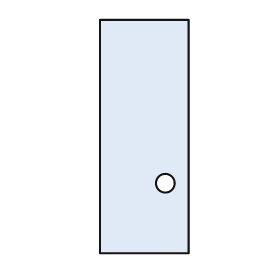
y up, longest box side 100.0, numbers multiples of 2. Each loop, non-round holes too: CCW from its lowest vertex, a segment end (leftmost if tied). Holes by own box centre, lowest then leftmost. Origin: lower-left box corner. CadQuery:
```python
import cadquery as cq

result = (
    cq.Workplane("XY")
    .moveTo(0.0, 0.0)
    .lineTo(38.0, 0.0)
    .lineTo(38.0, 100.0)
    .lineTo(0.0, 100.0)
    .close()
    .moveTo(28.0, 30.0)
    .circle(4.0)
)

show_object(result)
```